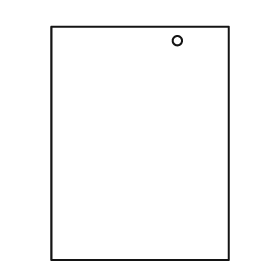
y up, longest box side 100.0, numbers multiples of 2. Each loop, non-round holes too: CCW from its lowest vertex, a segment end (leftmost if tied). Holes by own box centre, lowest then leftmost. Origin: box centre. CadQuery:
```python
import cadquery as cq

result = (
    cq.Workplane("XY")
    .moveTo(-38.0, -50.0)
    .lineTo(38.0, -50.0)
    .lineTo(38.0, 50.0)
    .lineTo(-38.0, 50.0)
    .close()
    .moveTo(16.0, 44.0)
    .circle(2.0)
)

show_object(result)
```